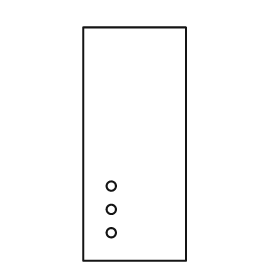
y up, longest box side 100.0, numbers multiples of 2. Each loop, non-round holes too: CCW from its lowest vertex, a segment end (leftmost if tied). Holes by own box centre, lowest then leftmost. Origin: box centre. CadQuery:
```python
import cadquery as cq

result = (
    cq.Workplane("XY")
    .moveTo(-22.0, -50.0)
    .lineTo(22.0, -50.0)
    .lineTo(22.0, 50.0)
    .lineTo(-22.0, 50.0)
    .close()
    .moveTo(-10.0, -38.0)
    .circle(2.0)
    .moveTo(-10.0, -28.0)
    .circle(2.0)
    .moveTo(-10.0, -18.0)
    .circle(2.0)
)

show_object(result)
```